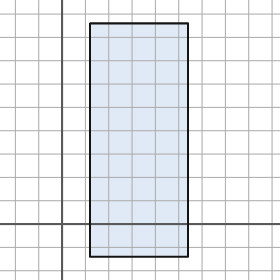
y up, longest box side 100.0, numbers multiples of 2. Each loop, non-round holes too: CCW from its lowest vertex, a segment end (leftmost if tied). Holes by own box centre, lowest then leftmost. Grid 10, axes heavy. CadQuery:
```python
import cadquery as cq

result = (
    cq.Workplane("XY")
    .moveTo(12.0, -14.0)
    .lineTo(54.0, -14.0)
    .lineTo(54.0, 86.0)
    .lineTo(12.0, 86.0)
    .close()
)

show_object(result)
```